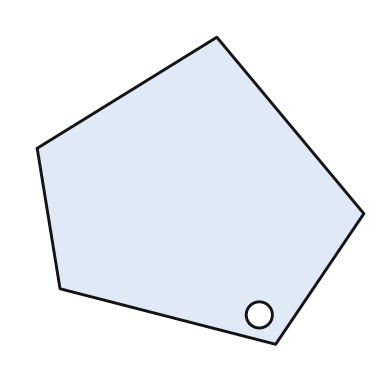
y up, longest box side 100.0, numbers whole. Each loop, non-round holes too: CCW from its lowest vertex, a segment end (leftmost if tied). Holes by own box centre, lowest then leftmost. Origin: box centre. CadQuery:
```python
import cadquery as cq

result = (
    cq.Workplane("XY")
    .moveTo(23.0, -47.0)
    .lineTo(50.0, -7.0)
    .lineTo(5.0, 47.0)
    .lineTo(-50.0, 13.0)
    .lineTo(-43.0, -30.0)
    .close()
    .moveTo(18.0, -38.0)
    .circle(4.0)
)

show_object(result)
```